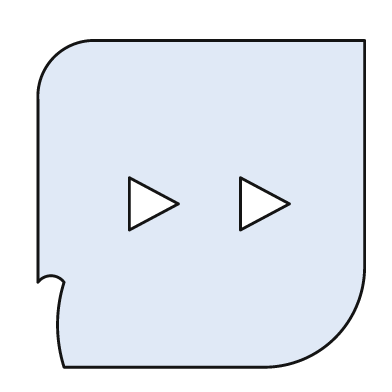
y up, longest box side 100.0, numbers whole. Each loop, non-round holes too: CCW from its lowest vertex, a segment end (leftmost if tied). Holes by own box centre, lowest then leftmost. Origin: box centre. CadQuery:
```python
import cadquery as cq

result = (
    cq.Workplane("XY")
    .moveTo(-42.0, -50.0)
    .lineTo(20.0, -50.0)
    .threePointArc((41.0, -41.0), (50.0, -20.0))
    .lineTo(50.0, 50.0)
    .lineTo(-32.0, 50.0)
    .threePointArc((-45.0, 45.0), (-50.0, 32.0))
    .lineTo(-50.0, -24.0)
    .threePointArc((-46.0, -22.0), (-42.0, -24.0))
    .threePointArc((-44.0, -37.0), (-42.0, -50.0))
    .close()
    .moveTo(-22.0, -8.0)
    .lineTo(-7.0, 0.0)
    .lineTo(-22.0, 8.0)
    .close()
    .moveTo(12.0, -8.0)
    .lineTo(27.0, 0.0)
    .lineTo(12.0, 8.0)
    .close()
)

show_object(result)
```